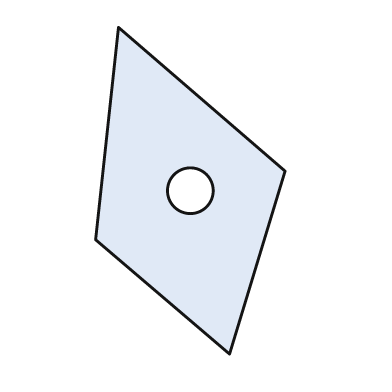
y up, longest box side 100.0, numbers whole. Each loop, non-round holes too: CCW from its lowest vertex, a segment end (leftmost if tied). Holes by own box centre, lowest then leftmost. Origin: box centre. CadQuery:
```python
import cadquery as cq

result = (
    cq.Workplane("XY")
    .moveTo(12.0, -50.0)
    .lineTo(29.0, 6.0)
    .lineTo(-22.0, 50.0)
    .lineTo(-29.0, -15.0)
    .close()
    .moveTo(0.0, 0.0)
    .circle(7.0)
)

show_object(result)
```